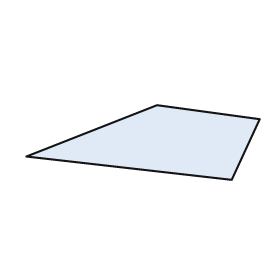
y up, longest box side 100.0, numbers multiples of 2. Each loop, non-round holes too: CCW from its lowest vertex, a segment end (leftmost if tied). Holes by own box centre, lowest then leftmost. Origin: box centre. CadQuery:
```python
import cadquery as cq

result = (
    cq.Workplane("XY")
    .moveTo(38.0, -16.0)
    .lineTo(50.0, 10.0)
    .lineTo(6.0, 16.0)
    .lineTo(-50.0, -6.0)
    .close()
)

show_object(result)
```